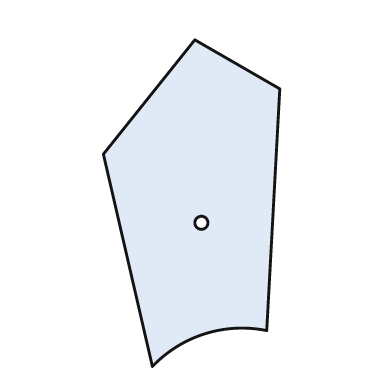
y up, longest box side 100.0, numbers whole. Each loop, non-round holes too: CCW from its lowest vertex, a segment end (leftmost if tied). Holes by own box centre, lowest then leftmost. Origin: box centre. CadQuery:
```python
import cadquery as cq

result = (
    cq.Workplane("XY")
    .moveTo(-12.0, -50.0)
    .threePointArc((4.0, -40.0), (23.0, -39.0))
    .lineTo(27.0, 35.0)
    .lineTo(1.0, 50.0)
    .lineTo(-27.0, 15.0)
    .close()
    .moveTo(3.0, -6.0)
    .circle(2.0)
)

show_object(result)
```